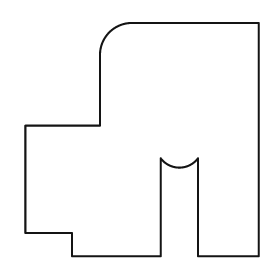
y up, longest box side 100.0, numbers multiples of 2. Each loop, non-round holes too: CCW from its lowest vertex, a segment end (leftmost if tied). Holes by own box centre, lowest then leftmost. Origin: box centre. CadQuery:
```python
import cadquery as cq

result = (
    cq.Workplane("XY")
    .moveTo(-30.0, -50.0)
    .lineTo(8.0, -50.0)
    .lineTo(8.0, -8.0)
    .threePointArc((16.0, -12.0), (24.0, -8.0))
    .lineTo(24.0, -50.0)
    .lineTo(50.0, -50.0)
    .lineTo(50.0, 50.0)
    .lineTo(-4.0, 50.0)
    .threePointArc((-14.0, 46.0), (-18.0, 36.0))
    .lineTo(-18.0, 6.0)
    .lineTo(-50.0, 6.0)
    .lineTo(-50.0, -40.0)
    .lineTo(-30.0, -40.0)
    .close()
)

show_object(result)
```